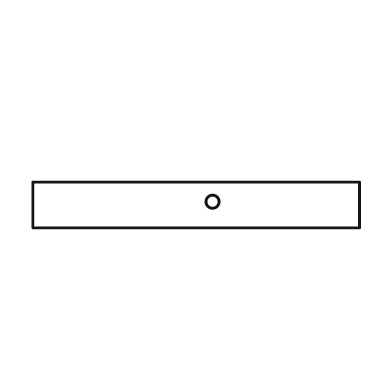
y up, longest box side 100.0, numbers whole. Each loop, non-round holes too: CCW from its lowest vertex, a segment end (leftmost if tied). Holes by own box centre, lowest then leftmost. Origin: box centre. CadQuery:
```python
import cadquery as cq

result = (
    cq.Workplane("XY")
    .moveTo(-50.0, -7.0)
    .lineTo(50.0, -7.0)
    .lineTo(50.0, 7.0)
    .lineTo(-50.0, 7.0)
    .close()
    .moveTo(5.0, 1.0)
    .circle(2.0)
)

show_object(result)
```